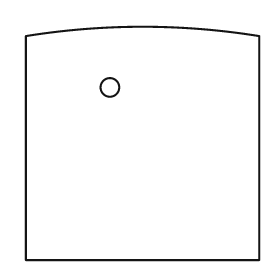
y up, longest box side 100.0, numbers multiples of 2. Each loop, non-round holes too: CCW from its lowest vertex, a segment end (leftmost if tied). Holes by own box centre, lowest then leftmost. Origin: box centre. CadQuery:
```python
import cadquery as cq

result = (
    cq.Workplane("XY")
    .moveTo(-50.0, -50.0)
    .lineTo(50.0, -50.0)
    .lineTo(50.0, 46.0)
    .threePointArc((0.0, 50.0), (-50.0, 46.0))
    .close()
    .moveTo(-14.0, 24.0)
    .circle(4.0)
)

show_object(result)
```